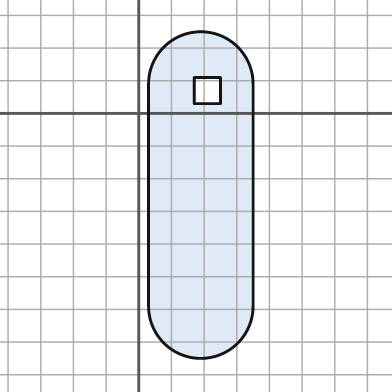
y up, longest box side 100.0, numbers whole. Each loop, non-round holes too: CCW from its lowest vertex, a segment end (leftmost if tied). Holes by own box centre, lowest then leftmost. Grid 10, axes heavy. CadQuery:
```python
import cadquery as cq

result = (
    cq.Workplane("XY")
    .moveTo(3.0, -59.0)
    .threePointArc((19.0, -75.0), (35.0, -59.0))
    .lineTo(35.0, 9.0)
    .threePointArc((19.0, 25.0), (3.0, 9.0))
    .close()
    .moveTo(17.0, 3.0)
    .lineTo(25.0, 3.0)
    .lineTo(25.0, 11.0)
    .lineTo(17.0, 11.0)
    .close()
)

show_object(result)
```